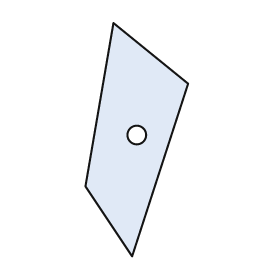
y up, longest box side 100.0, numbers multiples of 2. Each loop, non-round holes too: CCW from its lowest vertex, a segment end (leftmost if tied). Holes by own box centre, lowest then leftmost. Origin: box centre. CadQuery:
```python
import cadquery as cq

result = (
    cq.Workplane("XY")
    .moveTo(-2.0, -50.0)
    .lineTo(22.0, 24.0)
    .lineTo(-10.0, 50.0)
    .lineTo(-22.0, -20.0)
    .close()
    .moveTo(0.0, 2.0)
    .circle(4.0)
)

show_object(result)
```